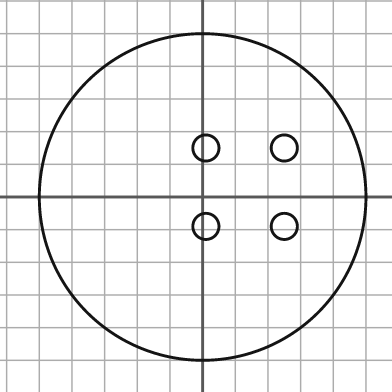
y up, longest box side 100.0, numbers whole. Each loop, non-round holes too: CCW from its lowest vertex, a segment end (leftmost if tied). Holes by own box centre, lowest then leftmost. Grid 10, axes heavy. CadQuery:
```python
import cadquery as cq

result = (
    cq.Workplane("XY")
    .moveTo(0.0, 0.0)
    .circle(50.0)
    .moveTo(1.0, -9.0)
    .circle(4.0)
    .moveTo(25.0, -9.0)
    .circle(4.0)
    .moveTo(1.0, 15.0)
    .circle(4.0)
    .moveTo(25.0, 15.0)
    .circle(4.0)
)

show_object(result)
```